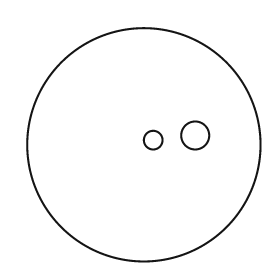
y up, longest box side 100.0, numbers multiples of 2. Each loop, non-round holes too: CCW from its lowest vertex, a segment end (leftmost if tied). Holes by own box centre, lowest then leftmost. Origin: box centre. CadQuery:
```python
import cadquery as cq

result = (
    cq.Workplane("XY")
    .moveTo(0.0, 0.0)
    .circle(50.0)
    .moveTo(4.0, 2.0)
    .circle(4.0)
    .moveTo(22.0, 4.0)
    .circle(6.0)
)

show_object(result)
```